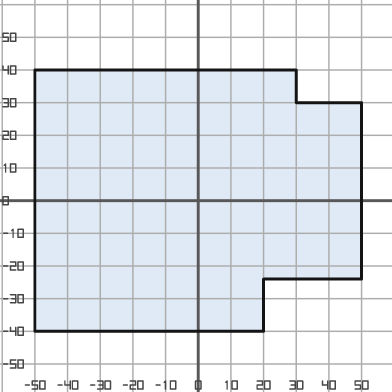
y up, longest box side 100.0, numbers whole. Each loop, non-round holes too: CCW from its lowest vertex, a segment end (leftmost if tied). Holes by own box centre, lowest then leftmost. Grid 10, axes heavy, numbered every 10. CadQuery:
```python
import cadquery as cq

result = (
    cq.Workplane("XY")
    .moveTo(-50.0, -40.0)
    .lineTo(20.0, -40.0)
    .lineTo(20.0, -24.0)
    .lineTo(50.0, -24.0)
    .lineTo(50.0, 30.0)
    .lineTo(30.0, 30.0)
    .lineTo(30.0, 40.0)
    .lineTo(-50.0, 40.0)
    .close()
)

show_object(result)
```